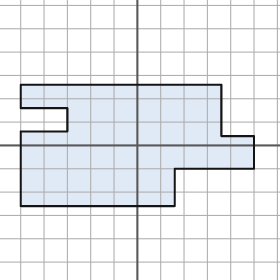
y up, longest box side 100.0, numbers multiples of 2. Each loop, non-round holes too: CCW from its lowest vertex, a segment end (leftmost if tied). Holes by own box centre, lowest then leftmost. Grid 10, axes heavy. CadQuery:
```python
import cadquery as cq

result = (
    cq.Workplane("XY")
    .moveTo(-50.0, -26.0)
    .lineTo(16.0, -26.0)
    .lineTo(16.0, -10.0)
    .lineTo(50.0, -10.0)
    .lineTo(50.0, 4.0)
    .lineTo(36.0, 4.0)
    .lineTo(36.0, 26.0)
    .lineTo(-50.0, 26.0)
    .lineTo(-50.0, 16.0)
    .lineTo(-30.0, 16.0)
    .lineTo(-30.0, 6.0)
    .lineTo(-50.0, 6.0)
    .close()
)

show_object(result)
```